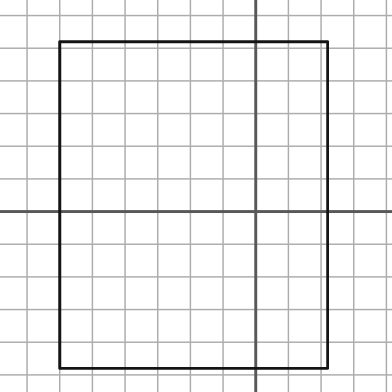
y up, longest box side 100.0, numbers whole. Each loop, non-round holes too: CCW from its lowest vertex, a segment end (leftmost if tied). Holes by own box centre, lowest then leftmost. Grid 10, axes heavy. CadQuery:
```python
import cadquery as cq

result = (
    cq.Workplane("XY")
    .moveTo(-60.0, -48.0)
    .lineTo(22.0, -48.0)
    .lineTo(22.0, 52.0)
    .lineTo(-60.0, 52.0)
    .close()
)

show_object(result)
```